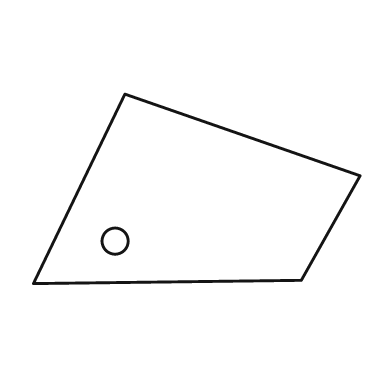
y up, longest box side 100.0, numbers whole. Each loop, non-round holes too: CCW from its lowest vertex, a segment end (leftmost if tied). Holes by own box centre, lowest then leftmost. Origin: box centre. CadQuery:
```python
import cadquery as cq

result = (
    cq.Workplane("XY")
    .moveTo(-50.0, -29.0)
    .lineTo(32.0, -28.0)
    .lineTo(50.0, 4.0)
    .lineTo(-22.0, 29.0)
    .close()
    .moveTo(-25.0, -16.0)
    .circle(4.0)
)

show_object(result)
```